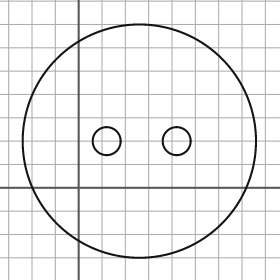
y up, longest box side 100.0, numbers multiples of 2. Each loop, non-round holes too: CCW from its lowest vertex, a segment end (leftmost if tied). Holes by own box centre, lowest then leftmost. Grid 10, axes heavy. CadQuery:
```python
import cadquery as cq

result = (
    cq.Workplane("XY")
    .moveTo(26.0, 20.0)
    .circle(50.0)
    .moveTo(12.0, 20.0)
    .circle(6.0)
    .moveTo(42.0, 20.0)
    .circle(6.0)
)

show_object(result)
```